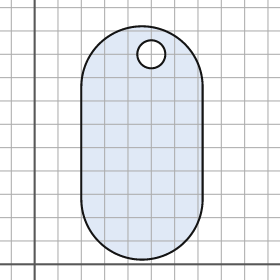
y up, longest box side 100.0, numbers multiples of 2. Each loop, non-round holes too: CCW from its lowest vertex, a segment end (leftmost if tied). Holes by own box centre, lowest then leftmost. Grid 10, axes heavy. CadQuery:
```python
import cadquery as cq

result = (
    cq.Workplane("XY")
    .moveTo(20.0, 28.0)
    .threePointArc((46.0, 2.0), (72.0, 28.0))
    .lineTo(72.0, 76.0)
    .threePointArc((46.0, 102.0), (20.0, 76.0))
    .close()
    .moveTo(50.0, 90.0)
    .circle(6.0)
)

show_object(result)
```